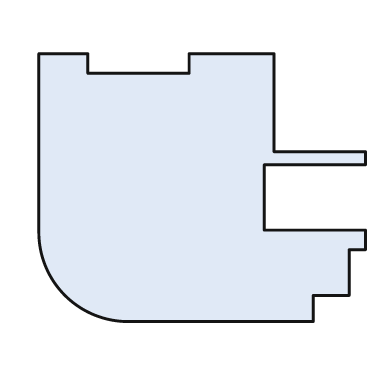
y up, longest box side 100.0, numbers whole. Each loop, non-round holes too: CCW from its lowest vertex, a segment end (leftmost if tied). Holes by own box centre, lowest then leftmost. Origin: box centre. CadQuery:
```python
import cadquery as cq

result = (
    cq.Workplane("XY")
    .moveTo(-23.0, -41.0)
    .lineTo(34.0, -41.0)
    .lineTo(34.0, -33.0)
    .lineTo(45.0, -33.0)
    .lineTo(45.0, -19.0)
    .lineTo(50.0, -19.0)
    .lineTo(50.0, -13.0)
    .lineTo(19.0, -13.0)
    .lineTo(19.0, 7.0)
    .lineTo(50.0, 7.0)
    .lineTo(50.0, 11.0)
    .lineTo(22.0, 11.0)
    .lineTo(22.0, 41.0)
    .lineTo(-4.0, 41.0)
    .lineTo(-4.0, 35.0)
    .lineTo(-35.0, 35.0)
    .lineTo(-35.0, 41.0)
    .lineTo(-50.0, 41.0)
    .lineTo(-50.0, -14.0)
    .threePointArc((-42.0, -33.0), (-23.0, -41.0))
    .close()
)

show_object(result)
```